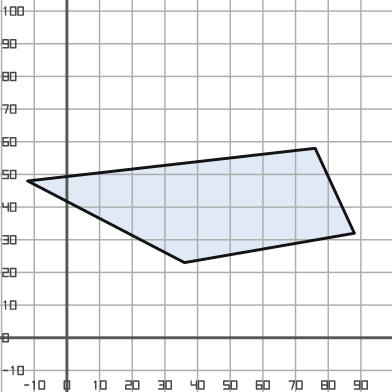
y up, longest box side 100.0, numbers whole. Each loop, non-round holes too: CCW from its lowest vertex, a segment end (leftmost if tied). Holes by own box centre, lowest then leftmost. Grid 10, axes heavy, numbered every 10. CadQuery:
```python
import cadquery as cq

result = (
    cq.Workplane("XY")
    .moveTo(36.0, 23.0)
    .lineTo(88.0, 32.0)
    .lineTo(76.0, 58.0)
    .lineTo(-12.0, 48.0)
    .close()
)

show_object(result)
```